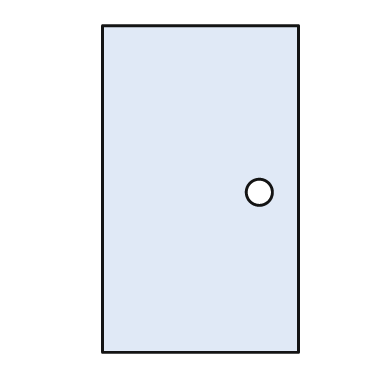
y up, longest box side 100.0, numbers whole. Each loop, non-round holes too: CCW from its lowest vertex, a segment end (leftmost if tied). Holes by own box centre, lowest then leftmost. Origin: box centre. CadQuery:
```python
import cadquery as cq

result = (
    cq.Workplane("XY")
    .moveTo(-30.0, -50.0)
    .lineTo(30.0, -50.0)
    .lineTo(30.0, 50.0)
    .lineTo(-30.0, 50.0)
    .close()
    .moveTo(18.0, -1.0)
    .circle(4.0)
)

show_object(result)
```